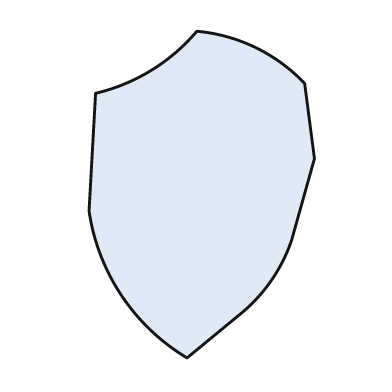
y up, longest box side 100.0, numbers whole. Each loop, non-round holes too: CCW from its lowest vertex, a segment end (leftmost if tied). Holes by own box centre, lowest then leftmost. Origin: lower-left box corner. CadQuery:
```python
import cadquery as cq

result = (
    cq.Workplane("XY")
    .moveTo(30.0, 0.0)
    .lineTo(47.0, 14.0)
    .threePointArc((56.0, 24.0), (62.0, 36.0))
    .lineTo(69.0, 61.0)
    .lineTo(66.0, 84.0)
    .threePointArc((51.0, 95.0), (33.0, 100.0))
    .threePointArc((19.0, 88.0), (2.0, 81.0))
    .lineTo(0.0, 45.0)
    .threePointArc((10.0, 19.0), (30.0, 0.0))
    .close()
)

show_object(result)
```